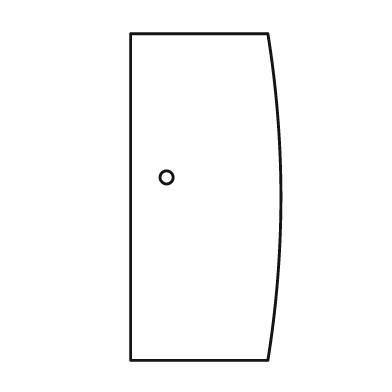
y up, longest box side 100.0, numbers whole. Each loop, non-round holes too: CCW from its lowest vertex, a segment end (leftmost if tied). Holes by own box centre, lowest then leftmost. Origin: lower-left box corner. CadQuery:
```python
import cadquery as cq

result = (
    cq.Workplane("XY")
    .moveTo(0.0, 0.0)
    .lineTo(42.0, 0.0)
    .threePointArc((46.0, 50.0), (42.0, 100.0))
    .lineTo(0.0, 100.0)
    .close()
    .moveTo(11.0, 56.0)
    .circle(2.0)
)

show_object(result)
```